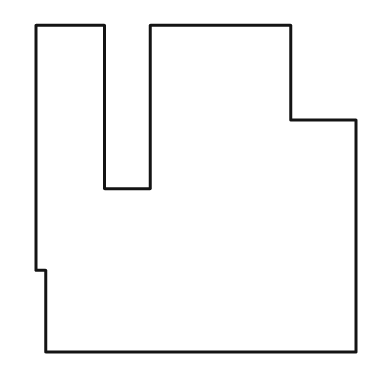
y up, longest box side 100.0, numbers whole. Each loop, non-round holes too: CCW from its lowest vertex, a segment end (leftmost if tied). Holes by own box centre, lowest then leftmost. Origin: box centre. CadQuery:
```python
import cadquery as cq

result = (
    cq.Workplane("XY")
    .moveTo(-46.0, -50.0)
    .lineTo(49.0, -50.0)
    .lineTo(49.0, 21.0)
    .lineTo(29.0, 21.0)
    .lineTo(29.0, 50.0)
    .lineTo(-14.0, 50.0)
    .lineTo(-14.0, 0.0)
    .lineTo(-28.0, 0.0)
    .lineTo(-28.0, 50.0)
    .lineTo(-49.0, 50.0)
    .lineTo(-49.0, -25.0)
    .lineTo(-46.0, -25.0)
    .close()
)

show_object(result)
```